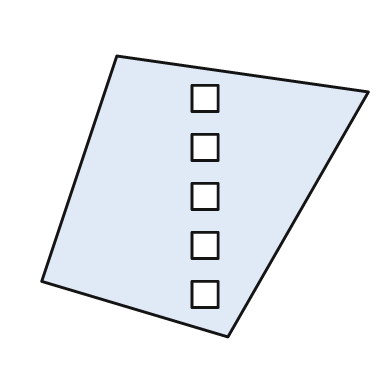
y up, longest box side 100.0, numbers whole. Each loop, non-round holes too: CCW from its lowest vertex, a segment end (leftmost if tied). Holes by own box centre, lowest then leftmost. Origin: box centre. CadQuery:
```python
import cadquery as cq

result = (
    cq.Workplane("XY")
    .moveTo(7.0, -43.0)
    .lineTo(50.0, 32.0)
    .lineTo(-27.0, 43.0)
    .lineTo(-50.0, -26.0)
    .close()
    .moveTo(-4.0, -34.0)
    .lineTo(4.0, -34.0)
    .lineTo(4.0, -26.0)
    .lineTo(-4.0, -26.0)
    .close()
    .moveTo(-4.0, -19.0)
    .lineTo(4.0, -19.0)
    .lineTo(4.0, -11.0)
    .lineTo(-4.0, -11.0)
    .close()
    .moveTo(-4.0, -4.0)
    .lineTo(4.0, -4.0)
    .lineTo(4.0, 4.0)
    .lineTo(-4.0, 4.0)
    .close()
    .moveTo(-4.0, 11.0)
    .lineTo(4.0, 11.0)
    .lineTo(4.0, 19.0)
    .lineTo(-4.0, 19.0)
    .close()
    .moveTo(-4.0, 26.0)
    .lineTo(4.0, 26.0)
    .lineTo(4.0, 34.0)
    .lineTo(-4.0, 34.0)
    .close()
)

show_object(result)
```